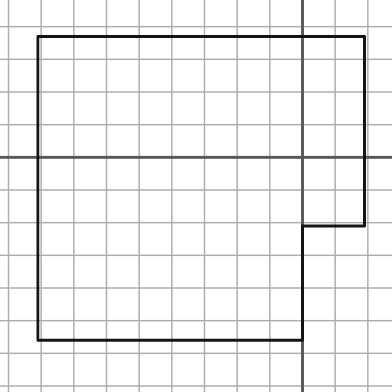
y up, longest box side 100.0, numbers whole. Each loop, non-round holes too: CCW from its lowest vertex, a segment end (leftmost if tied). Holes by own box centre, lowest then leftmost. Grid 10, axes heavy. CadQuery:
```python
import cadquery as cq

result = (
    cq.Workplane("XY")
    .moveTo(-81.0, -56.0)
    .lineTo(0.0, -56.0)
    .lineTo(0.0, -21.0)
    .lineTo(19.0, -21.0)
    .lineTo(19.0, 37.0)
    .lineTo(-81.0, 37.0)
    .close()
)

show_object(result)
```